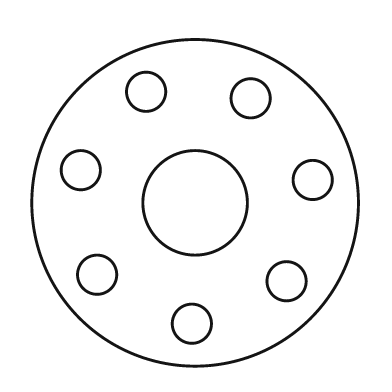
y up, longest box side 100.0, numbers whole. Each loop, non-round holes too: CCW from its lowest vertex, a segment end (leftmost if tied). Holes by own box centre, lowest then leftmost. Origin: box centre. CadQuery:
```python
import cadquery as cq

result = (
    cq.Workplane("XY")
    .moveTo(0.0, 0.0)
    .circle(50.0)
    .moveTo(-1.0, -37.0)
    .circle(6.0)
    .moveTo(28.0, -24.0)
    .circle(6.0)
    .moveTo(-30.0, -22.0)
    .circle(6.0)
    .moveTo(0.0, 0.0)
    .circle(16.0)
    .moveTo(36.0, 7.0)
    .circle(6.0)
    .moveTo(-35.0, 10.0)
    .circle(6.0)
    .moveTo(17.0, 32.0)
    .circle(6.0)
    .moveTo(-15.0, 34.0)
    .circle(6.0)
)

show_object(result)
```